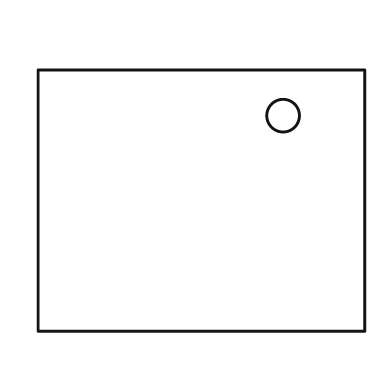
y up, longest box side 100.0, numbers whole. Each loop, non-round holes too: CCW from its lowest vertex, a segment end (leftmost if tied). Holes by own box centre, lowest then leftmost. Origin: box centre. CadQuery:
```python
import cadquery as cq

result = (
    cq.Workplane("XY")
    .moveTo(-50.0, -40.0)
    .lineTo(50.0, -40.0)
    .lineTo(50.0, 40.0)
    .lineTo(-50.0, 40.0)
    .close()
    .moveTo(25.0, 26.0)
    .circle(5.0)
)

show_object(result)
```